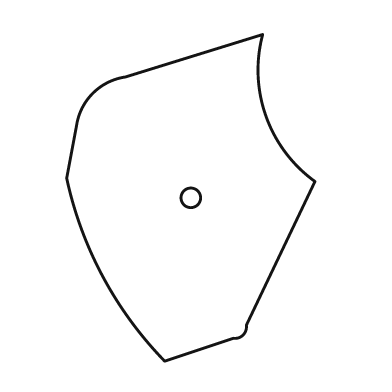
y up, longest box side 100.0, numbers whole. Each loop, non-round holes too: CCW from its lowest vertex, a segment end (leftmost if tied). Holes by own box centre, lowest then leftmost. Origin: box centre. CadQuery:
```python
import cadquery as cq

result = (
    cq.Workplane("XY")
    .moveTo(-8.0, -50.0)
    .lineTo(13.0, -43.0)
    .threePointArc((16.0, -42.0), (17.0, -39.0))
    .lineTo(38.0, 5.0)
    .threePointArc((23.0, 25.0), (22.0, 50.0))
    .lineTo(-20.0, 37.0)
    .threePointArc((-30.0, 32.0), (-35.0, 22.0))
    .lineTo(-38.0, 6.0)
    .threePointArc((-27.0, -24.0), (-8.0, -50.0))
    .close()
    .moveTo(0.0, 0.0)
    .circle(3.0)
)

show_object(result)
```